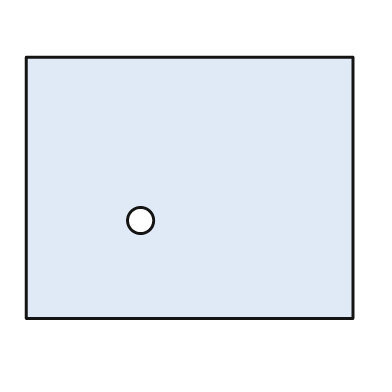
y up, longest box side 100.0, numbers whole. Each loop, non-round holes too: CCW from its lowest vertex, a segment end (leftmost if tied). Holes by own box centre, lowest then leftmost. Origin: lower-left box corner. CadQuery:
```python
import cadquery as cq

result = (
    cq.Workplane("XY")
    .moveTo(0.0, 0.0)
    .lineTo(100.0, 0.0)
    .lineTo(100.0, 80.0)
    .lineTo(0.0, 80.0)
    .close()
    .moveTo(35.0, 30.0)
    .circle(4.0)
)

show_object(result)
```